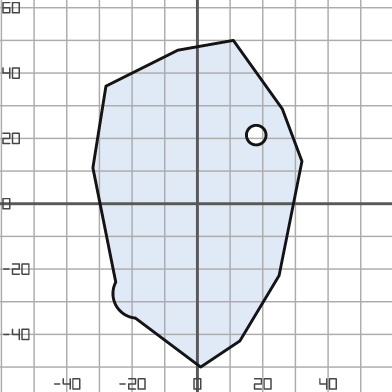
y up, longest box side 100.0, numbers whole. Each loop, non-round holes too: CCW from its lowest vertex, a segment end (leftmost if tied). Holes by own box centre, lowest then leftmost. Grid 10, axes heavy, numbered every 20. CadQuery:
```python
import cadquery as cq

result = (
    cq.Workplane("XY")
    .moveTo(1.0, -50.0)
    .lineTo(13.0, -42.0)
    .lineTo(25.0, -22.0)
    .lineTo(32.0, 13.0)
    .lineTo(26.0, 29.0)
    .lineTo(11.0, 50.0)
    .lineTo(-6.0, 47.0)
    .lineTo(-28.0, 36.0)
    .lineTo(-32.0, 11.0)
    .lineTo(-25.0, -24.0)
    .threePointArc((-25.0, -31.0), (-19.0, -35.0))
    .close()
    .moveTo(18.0, 21.0)
    .circle(3.0)
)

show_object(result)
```